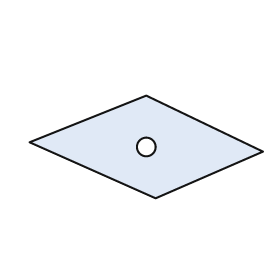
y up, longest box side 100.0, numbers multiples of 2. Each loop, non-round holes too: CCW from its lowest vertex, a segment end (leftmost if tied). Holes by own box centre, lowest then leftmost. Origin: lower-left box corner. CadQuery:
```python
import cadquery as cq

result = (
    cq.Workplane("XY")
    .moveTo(54.0, 0.0)
    .lineTo(100.0, 20.0)
    .lineTo(50.0, 44.0)
    .lineTo(0.0, 24.0)
    .close()
    .moveTo(50.0, 22.0)
    .circle(4.0)
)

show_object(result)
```